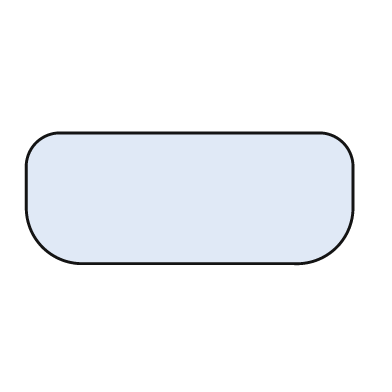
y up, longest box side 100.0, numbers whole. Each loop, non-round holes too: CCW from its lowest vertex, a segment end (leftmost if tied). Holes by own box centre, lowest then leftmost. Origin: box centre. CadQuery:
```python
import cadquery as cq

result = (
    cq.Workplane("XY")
    .moveTo(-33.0, -20.0)
    .lineTo(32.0, -20.0)
    .threePointArc((45.0, -15.0), (50.0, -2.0))
    .lineTo(50.0, 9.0)
    .threePointArc((47.0, 17.0), (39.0, 20.0))
    .lineTo(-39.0, 20.0)
    .threePointArc((-47.0, 17.0), (-50.0, 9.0))
    .lineTo(-50.0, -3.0)
    .threePointArc((-45.0, -15.0), (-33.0, -20.0))
    .close()
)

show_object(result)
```